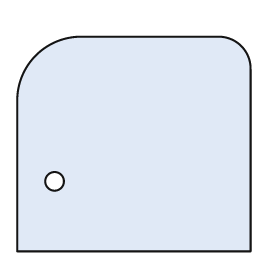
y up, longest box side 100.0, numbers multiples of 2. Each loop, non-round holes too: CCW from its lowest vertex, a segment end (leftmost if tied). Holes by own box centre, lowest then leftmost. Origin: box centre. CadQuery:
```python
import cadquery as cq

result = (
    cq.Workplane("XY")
    .moveTo(-50.0, -46.0)
    .lineTo(50.0, -46.0)
    .lineTo(50.0, 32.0)
    .threePointArc((46.0, 42.0), (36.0, 46.0))
    .lineTo(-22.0, 46.0)
    .threePointArc((-42.0, 38.0), (-50.0, 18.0))
    .close()
    .moveTo(-34.0, -16.0)
    .circle(4.0)
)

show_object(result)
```